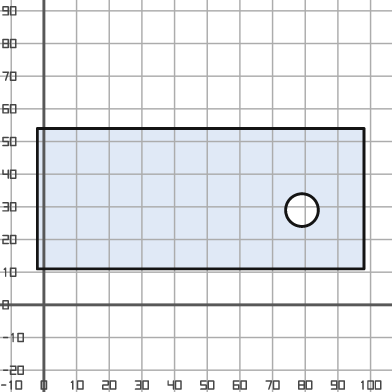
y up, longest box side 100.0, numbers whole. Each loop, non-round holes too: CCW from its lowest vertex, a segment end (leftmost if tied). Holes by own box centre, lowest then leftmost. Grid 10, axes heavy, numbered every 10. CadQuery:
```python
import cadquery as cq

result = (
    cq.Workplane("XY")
    .moveTo(-2.0, 11.0)
    .lineTo(98.0, 11.0)
    .lineTo(98.0, 54.0)
    .lineTo(-2.0, 54.0)
    .close()
    .moveTo(79.0, 29.0)
    .circle(5.0)
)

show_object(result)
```